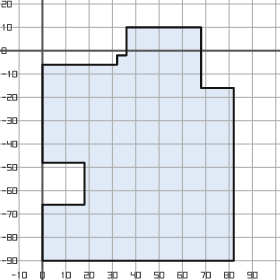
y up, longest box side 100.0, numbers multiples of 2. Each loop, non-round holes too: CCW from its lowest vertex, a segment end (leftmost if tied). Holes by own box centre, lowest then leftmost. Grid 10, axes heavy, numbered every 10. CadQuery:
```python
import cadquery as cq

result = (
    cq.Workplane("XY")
    .moveTo(0.0, -90.0)
    .lineTo(82.0, -90.0)
    .lineTo(82.0, -16.0)
    .lineTo(68.0, -16.0)
    .lineTo(68.0, 10.0)
    .lineTo(36.0, 10.0)
    .lineTo(36.0, -2.0)
    .lineTo(32.0, -2.0)
    .lineTo(32.0, -6.0)
    .lineTo(0.0, -6.0)
    .lineTo(0.0, -48.0)
    .lineTo(18.0, -48.0)
    .lineTo(18.0, -66.0)
    .lineTo(0.0, -66.0)
    .close()
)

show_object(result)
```